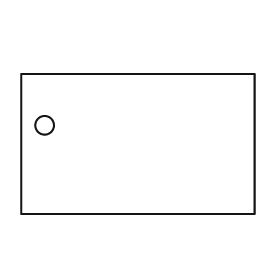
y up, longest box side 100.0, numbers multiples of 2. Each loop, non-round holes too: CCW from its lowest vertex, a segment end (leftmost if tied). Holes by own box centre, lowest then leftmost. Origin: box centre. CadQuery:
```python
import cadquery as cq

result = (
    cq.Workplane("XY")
    .moveTo(-50.0, -30.0)
    .lineTo(50.0, -30.0)
    .lineTo(50.0, 30.0)
    .lineTo(-50.0, 30.0)
    .close()
    .moveTo(-40.0, 8.0)
    .circle(4.0)
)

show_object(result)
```